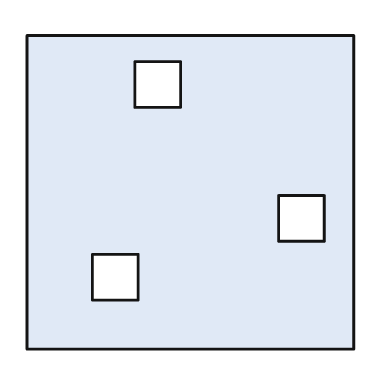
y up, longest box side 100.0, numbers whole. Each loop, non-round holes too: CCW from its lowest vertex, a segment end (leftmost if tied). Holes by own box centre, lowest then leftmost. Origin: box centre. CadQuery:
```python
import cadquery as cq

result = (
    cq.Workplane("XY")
    .moveTo(-50.0, -48.0)
    .lineTo(50.0, -48.0)
    .lineTo(50.0, 48.0)
    .lineTo(-50.0, 48.0)
    .close()
    .moveTo(-30.0, -33.0)
    .lineTo(-16.0, -33.0)
    .lineTo(-16.0, -19.0)
    .lineTo(-30.0, -19.0)
    .close()
    .moveTo(27.0, -15.0)
    .lineTo(41.0, -15.0)
    .lineTo(41.0, -1.0)
    .lineTo(27.0, -1.0)
    .close()
    .moveTo(-17.0, 26.0)
    .lineTo(-3.0, 26.0)
    .lineTo(-3.0, 40.0)
    .lineTo(-17.0, 40.0)
    .close()
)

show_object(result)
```